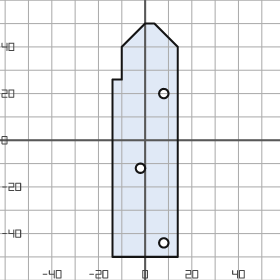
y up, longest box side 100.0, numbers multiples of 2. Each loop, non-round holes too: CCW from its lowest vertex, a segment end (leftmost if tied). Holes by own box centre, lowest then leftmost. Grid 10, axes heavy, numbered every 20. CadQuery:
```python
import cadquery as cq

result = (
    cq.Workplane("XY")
    .moveTo(-14.0, -50.0)
    .lineTo(14.0, -50.0)
    .lineTo(14.0, 40.0)
    .lineTo(4.0, 50.0)
    .lineTo(0.0, 50.0)
    .lineTo(-10.0, 40.0)
    .lineTo(-10.0, 26.0)
    .lineTo(-14.0, 26.0)
    .close()
    .moveTo(8.0, -44.0)
    .circle(2.0)
    .moveTo(-2.0, -12.0)
    .circle(2.0)
    .moveTo(8.0, 20.0)
    .circle(2.0)
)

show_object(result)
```